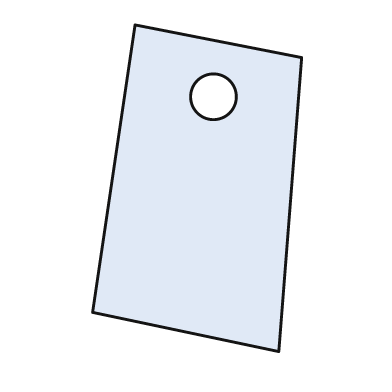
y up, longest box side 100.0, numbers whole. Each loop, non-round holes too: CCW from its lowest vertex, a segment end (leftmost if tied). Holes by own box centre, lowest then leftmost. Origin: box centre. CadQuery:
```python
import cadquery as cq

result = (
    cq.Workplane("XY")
    .moveTo(25.0, -50.0)
    .lineTo(32.0, 40.0)
    .lineTo(-19.0, 50.0)
    .lineTo(-32.0, -38.0)
    .close()
    .moveTo(5.0, 28.0)
    .circle(7.0)
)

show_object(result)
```